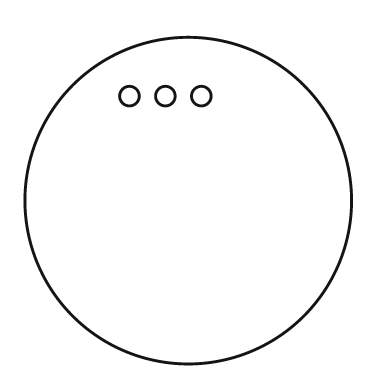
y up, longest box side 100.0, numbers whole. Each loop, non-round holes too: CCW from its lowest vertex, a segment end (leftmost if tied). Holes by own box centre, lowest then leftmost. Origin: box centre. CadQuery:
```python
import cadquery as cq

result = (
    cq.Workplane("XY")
    .moveTo(0.0, 0.0)
    .circle(50.0)
    .moveTo(-18.0, 32.0)
    .circle(3.0)
    .moveTo(-7.0, 32.0)
    .circle(3.0)
    .moveTo(4.0, 32.0)
    .circle(3.0)
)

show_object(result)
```